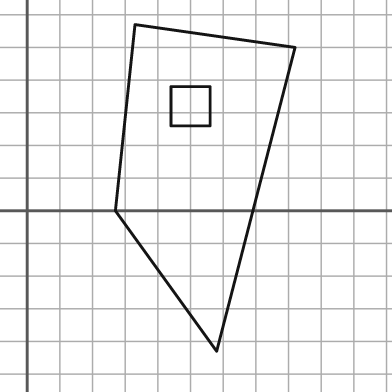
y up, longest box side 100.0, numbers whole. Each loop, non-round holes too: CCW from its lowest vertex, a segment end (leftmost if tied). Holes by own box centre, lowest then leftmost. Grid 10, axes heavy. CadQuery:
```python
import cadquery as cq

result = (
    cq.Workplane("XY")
    .moveTo(58.0, -43.0)
    .lineTo(82.0, 50.0)
    .lineTo(33.0, 57.0)
    .lineTo(27.0, 0.0)
    .close()
    .moveTo(44.0, 26.0)
    .lineTo(56.0, 26.0)
    .lineTo(56.0, 38.0)
    .lineTo(44.0, 38.0)
    .close()
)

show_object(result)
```